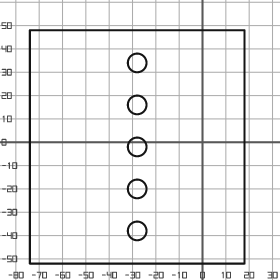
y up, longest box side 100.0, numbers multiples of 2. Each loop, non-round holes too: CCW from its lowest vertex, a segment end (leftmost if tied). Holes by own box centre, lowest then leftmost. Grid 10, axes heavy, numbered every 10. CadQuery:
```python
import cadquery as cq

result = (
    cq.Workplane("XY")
    .moveTo(-74.0, -52.0)
    .lineTo(18.0, -52.0)
    .lineTo(18.0, 48.0)
    .lineTo(-74.0, 48.0)
    .close()
    .moveTo(-28.0, -38.0)
    .circle(4.0)
    .moveTo(-28.0, -20.0)
    .circle(4.0)
    .moveTo(-28.0, -2.0)
    .circle(4.0)
    .moveTo(-28.0, 16.0)
    .circle(4.0)
    .moveTo(-28.0, 34.0)
    .circle(4.0)
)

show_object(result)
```